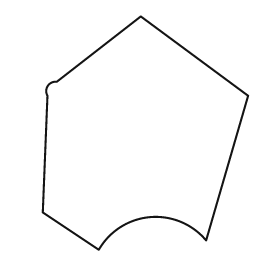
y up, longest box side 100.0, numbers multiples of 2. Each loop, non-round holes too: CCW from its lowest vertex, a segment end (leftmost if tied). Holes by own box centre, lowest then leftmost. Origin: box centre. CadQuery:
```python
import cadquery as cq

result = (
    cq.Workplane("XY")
    .moveTo(-20.0, -50.0)
    .threePointArc((2.0, -36.0), (26.0, -46.0))
    .lineTo(44.0, 16.0)
    .lineTo(-2.0, 50.0)
    .lineTo(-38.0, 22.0)
    .threePointArc((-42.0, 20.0), (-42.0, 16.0))
    .lineTo(-44.0, -34.0)
    .close()
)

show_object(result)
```